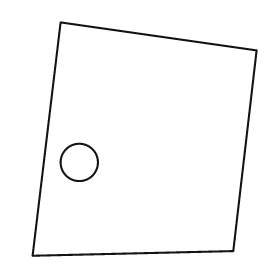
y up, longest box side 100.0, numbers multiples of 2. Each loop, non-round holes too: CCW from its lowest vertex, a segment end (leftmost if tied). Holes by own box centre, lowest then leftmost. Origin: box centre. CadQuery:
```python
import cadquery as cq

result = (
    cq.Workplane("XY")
    .moveTo(-48.0, -50.0)
    .lineTo(38.0, -48.0)
    .lineTo(48.0, 38.0)
    .lineTo(-36.0, 50.0)
    .close()
    .moveTo(-28.0, -10.0)
    .circle(8.0)
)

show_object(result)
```